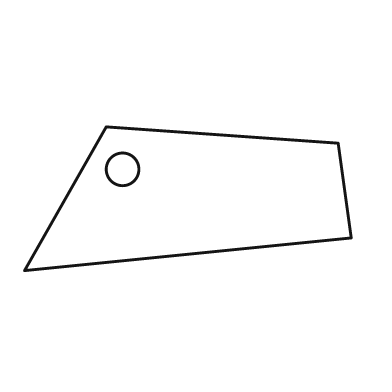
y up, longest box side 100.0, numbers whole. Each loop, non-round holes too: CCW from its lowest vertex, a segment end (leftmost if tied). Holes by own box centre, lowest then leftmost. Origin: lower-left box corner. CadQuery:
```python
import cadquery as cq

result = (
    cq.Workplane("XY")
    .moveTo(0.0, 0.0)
    .lineTo(100.0, 10.0)
    .lineTo(96.0, 39.0)
    .lineTo(25.0, 44.0)
    .close()
    .moveTo(30.0, 31.0)
    .circle(5.0)
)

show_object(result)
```